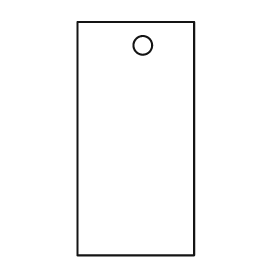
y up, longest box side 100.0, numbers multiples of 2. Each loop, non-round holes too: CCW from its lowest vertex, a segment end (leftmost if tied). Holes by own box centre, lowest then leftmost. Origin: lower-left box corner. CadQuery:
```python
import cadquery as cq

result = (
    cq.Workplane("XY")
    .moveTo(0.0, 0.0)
    .lineTo(50.0, 0.0)
    .lineTo(50.0, 100.0)
    .lineTo(0.0, 100.0)
    .close()
    .moveTo(28.0, 90.0)
    .circle(4.0)
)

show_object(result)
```